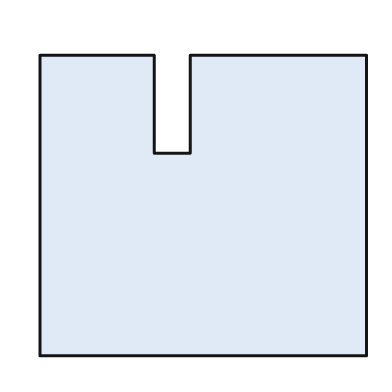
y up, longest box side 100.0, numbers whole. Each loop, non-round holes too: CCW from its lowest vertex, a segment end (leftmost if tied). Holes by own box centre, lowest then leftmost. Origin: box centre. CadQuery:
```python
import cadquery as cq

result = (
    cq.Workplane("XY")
    .moveTo(-50.0, -46.0)
    .lineTo(50.0, -46.0)
    .lineTo(50.0, 46.0)
    .lineTo(-4.0, 46.0)
    .lineTo(-4.0, 16.0)
    .lineTo(-15.0, 16.0)
    .lineTo(-15.0, 46.0)
    .lineTo(-50.0, 46.0)
    .close()
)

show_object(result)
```